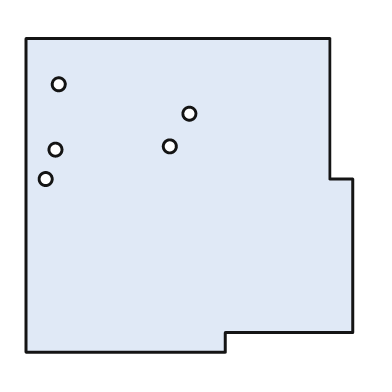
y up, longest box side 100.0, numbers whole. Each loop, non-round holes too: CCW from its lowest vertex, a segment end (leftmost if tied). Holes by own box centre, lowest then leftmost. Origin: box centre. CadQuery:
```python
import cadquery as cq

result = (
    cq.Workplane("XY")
    .moveTo(-50.0, -48.0)
    .lineTo(11.0, -48.0)
    .lineTo(11.0, -42.0)
    .lineTo(50.0, -42.0)
    .lineTo(50.0, 5.0)
    .lineTo(43.0, 5.0)
    .lineTo(43.0, 48.0)
    .lineTo(-50.0, 48.0)
    .close()
    .moveTo(-44.0, 5.0)
    .circle(2.0)
    .moveTo(-41.0, 14.0)
    .circle(2.0)
    .moveTo(-6.0, 15.0)
    .circle(2.0)
    .moveTo(0.0, 25.0)
    .circle(2.0)
    .moveTo(-40.0, 34.0)
    .circle(2.0)
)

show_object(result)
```